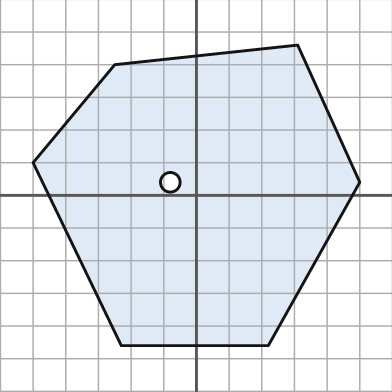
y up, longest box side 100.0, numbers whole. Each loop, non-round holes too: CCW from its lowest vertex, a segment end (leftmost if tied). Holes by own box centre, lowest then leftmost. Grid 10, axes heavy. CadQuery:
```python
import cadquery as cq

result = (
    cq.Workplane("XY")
    .moveTo(-23.0, -46.0)
    .lineTo(22.0, -46.0)
    .lineTo(50.0, 4.0)
    .lineTo(31.0, 46.0)
    .lineTo(-25.0, 40.0)
    .lineTo(-50.0, 10.0)
    .close()
    .moveTo(-8.0, 4.0)
    .circle(3.0)
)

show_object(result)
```